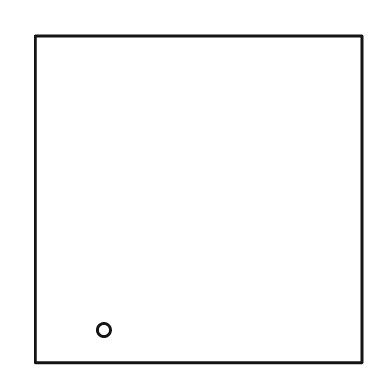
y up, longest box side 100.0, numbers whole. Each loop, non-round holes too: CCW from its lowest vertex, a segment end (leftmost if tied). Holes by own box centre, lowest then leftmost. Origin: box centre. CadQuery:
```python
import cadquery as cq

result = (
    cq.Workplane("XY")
    .moveTo(-50.0, -50.0)
    .lineTo(50.0, -50.0)
    .lineTo(50.0, 50.0)
    .lineTo(-50.0, 50.0)
    .close()
    .moveTo(-29.0, -40.0)
    .circle(2.0)
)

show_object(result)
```